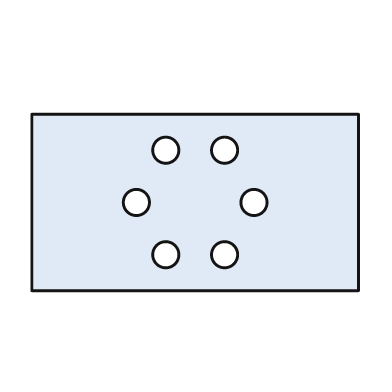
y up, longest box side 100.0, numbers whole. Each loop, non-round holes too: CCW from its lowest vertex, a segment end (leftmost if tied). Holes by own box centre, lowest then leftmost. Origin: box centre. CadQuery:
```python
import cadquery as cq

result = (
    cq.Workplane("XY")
    .moveTo(-50.0, -27.0)
    .lineTo(50.0, -27.0)
    .lineTo(50.0, 27.0)
    .lineTo(-50.0, 27.0)
    .close()
    .moveTo(-9.0, -16.0)
    .circle(4.0)
    .moveTo(9.0, -16.0)
    .circle(4.0)
    .moveTo(-18.0, 0.0)
    .circle(4.0)
    .moveTo(18.0, 0.0)
    .circle(4.0)
    .moveTo(-9.0, 16.0)
    .circle(4.0)
    .moveTo(9.0, 16.0)
    .circle(4.0)
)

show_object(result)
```